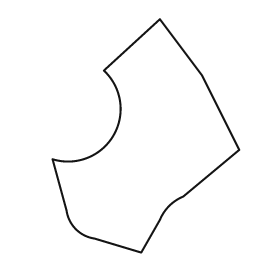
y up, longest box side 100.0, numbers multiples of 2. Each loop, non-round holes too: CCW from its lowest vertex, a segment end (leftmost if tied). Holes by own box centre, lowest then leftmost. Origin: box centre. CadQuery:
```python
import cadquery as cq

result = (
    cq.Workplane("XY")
    .moveTo(-2.0, -50.0)
    .lineTo(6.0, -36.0)
    .threePointArc((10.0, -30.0), (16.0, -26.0))
    .lineTo(40.0, -6.0)
    .lineTo(24.0, 26.0)
    .lineTo(6.0, 50.0)
    .lineTo(-18.0, 28.0)
    .threePointArc((-14.0, 0.0), (-40.0, -10.0))
    .lineTo(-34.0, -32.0)
    .threePointArc((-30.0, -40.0), (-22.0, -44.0))
    .close()
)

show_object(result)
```